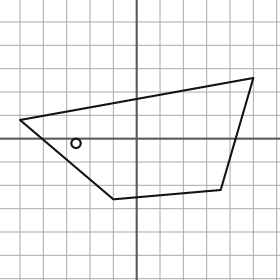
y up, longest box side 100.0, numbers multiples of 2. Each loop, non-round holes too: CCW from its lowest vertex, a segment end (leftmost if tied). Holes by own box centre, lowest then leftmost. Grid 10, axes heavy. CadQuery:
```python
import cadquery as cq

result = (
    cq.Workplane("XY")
    .moveTo(-10.0, -26.0)
    .lineTo(36.0, -22.0)
    .lineTo(50.0, 26.0)
    .lineTo(-50.0, 8.0)
    .close()
    .moveTo(-26.0, -2.0)
    .circle(2.0)
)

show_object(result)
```